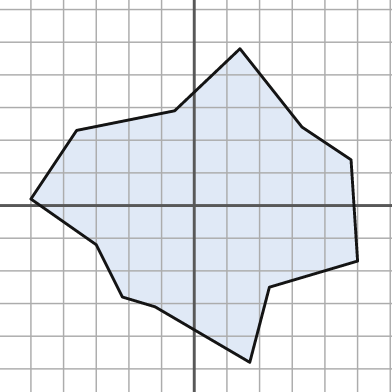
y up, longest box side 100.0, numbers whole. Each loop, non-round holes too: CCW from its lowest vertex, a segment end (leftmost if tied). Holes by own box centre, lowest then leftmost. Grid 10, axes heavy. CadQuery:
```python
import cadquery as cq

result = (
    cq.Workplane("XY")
    .moveTo(17.0, -48.0)
    .lineTo(23.0, -25.0)
    .lineTo(50.0, -17.0)
    .lineTo(48.0, 14.0)
    .lineTo(33.0, 24.0)
    .lineTo(14.0, 48.0)
    .lineTo(-6.0, 29.0)
    .lineTo(-36.0, 23.0)
    .lineTo(-50.0, 2.0)
    .lineTo(-30.0, -12.0)
    .lineTo(-22.0, -28.0)
    .lineTo(-12.0, -31.0)
    .close()
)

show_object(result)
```